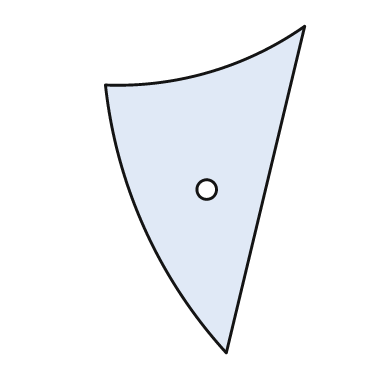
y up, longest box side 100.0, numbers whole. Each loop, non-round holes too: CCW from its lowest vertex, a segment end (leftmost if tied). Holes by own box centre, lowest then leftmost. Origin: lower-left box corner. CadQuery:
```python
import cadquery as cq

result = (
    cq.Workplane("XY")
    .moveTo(37.0, 0.0)
    .lineTo(61.0, 100.0)
    .threePointArc((32.0, 86.0), (0.0, 82.0))
    .threePointArc((12.0, 38.0), (37.0, 0.0))
    .close()
    .moveTo(31.0, 50.0)
    .circle(3.0)
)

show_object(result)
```